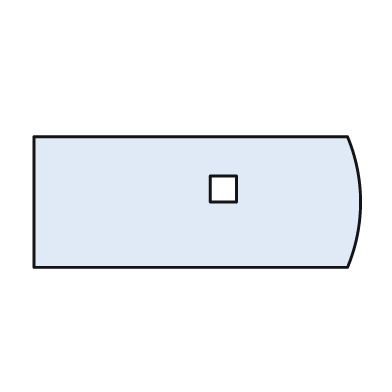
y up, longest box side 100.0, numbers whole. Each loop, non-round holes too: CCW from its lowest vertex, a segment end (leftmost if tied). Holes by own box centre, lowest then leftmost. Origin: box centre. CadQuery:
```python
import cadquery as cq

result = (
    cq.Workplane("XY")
    .moveTo(-50.0, -20.0)
    .lineTo(46.0, -20.0)
    .threePointArc((50.0, 0.0), (46.0, 20.0))
    .lineTo(-50.0, 20.0)
    .close()
    .moveTo(4.0, 0.0)
    .lineTo(12.0, 0.0)
    .lineTo(12.0, 8.0)
    .lineTo(4.0, 8.0)
    .close()
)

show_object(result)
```